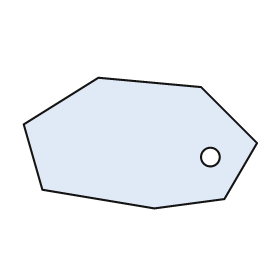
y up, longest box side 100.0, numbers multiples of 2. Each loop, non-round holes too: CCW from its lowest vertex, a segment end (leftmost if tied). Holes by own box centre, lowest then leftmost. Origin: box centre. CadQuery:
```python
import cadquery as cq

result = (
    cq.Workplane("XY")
    .moveTo(6.0, -28.0)
    .lineTo(36.0, -24.0)
    .lineTo(50.0, 0.0)
    .lineTo(26.0, 24.0)
    .lineTo(-18.0, 28.0)
    .lineTo(-50.0, 8.0)
    .lineTo(-42.0, -20.0)
    .close()
    .moveTo(30.0, -6.0)
    .circle(4.0)
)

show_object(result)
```